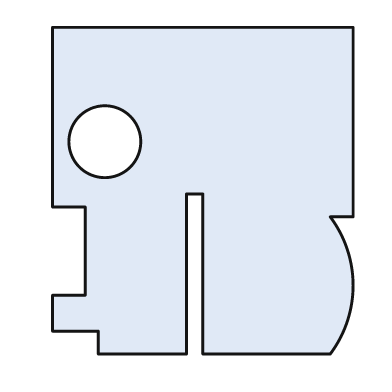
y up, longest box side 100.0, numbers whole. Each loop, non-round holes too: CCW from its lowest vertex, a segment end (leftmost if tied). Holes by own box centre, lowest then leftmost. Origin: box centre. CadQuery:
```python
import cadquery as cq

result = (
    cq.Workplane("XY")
    .moveTo(-32.0, -50.0)
    .lineTo(-5.0, -50.0)
    .lineTo(-5.0, -1.0)
    .lineTo(0.0, -1.0)
    .lineTo(0.0, -50.0)
    .lineTo(39.0, -50.0)
    .threePointArc((46.0, -29.0), (39.0, -8.0))
    .lineTo(46.0, -8.0)
    .lineTo(46.0, 50.0)
    .lineTo(-46.0, 50.0)
    .lineTo(-46.0, -5.0)
    .lineTo(-36.0, -5.0)
    .lineTo(-36.0, -32.0)
    .lineTo(-46.0, -32.0)
    .lineTo(-46.0, -43.0)
    .lineTo(-32.0, -43.0)
    .close()
    .moveTo(-30.0, 15.0)
    .circle(11.0)
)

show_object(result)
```